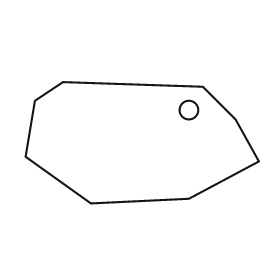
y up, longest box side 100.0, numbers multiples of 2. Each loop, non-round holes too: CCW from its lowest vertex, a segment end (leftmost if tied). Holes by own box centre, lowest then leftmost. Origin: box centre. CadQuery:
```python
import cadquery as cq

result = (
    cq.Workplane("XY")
    .moveTo(-22.0, -26.0)
    .lineTo(20.0, -24.0)
    .lineTo(50.0, -8.0)
    .lineTo(40.0, 10.0)
    .lineTo(26.0, 24.0)
    .lineTo(-34.0, 26.0)
    .lineTo(-46.0, 18.0)
    .lineTo(-50.0, -6.0)
    .close()
    .moveTo(20.0, 14.0)
    .circle(4.0)
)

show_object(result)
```